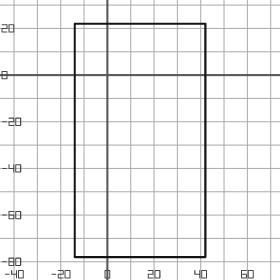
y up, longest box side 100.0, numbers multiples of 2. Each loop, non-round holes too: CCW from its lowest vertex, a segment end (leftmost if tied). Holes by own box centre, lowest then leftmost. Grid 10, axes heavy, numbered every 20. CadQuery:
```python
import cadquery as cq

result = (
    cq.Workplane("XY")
    .moveTo(-14.0, -78.0)
    .lineTo(42.0, -78.0)
    .lineTo(42.0, 22.0)
    .lineTo(-14.0, 22.0)
    .close()
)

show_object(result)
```